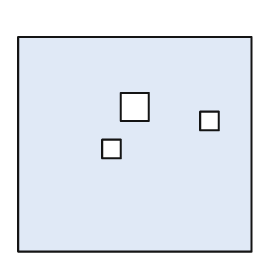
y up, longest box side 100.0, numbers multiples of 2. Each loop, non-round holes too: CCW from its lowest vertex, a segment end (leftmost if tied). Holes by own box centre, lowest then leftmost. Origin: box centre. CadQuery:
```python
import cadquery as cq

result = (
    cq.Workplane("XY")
    .moveTo(-50.0, -46.0)
    .lineTo(50.0, -46.0)
    .lineTo(50.0, 46.0)
    .lineTo(-50.0, 46.0)
    .close()
    .moveTo(-14.0, -6.0)
    .lineTo(-6.0, -6.0)
    .lineTo(-6.0, 2.0)
    .lineTo(-14.0, 2.0)
    .close()
    .moveTo(28.0, 6.0)
    .lineTo(36.0, 6.0)
    .lineTo(36.0, 14.0)
    .lineTo(28.0, 14.0)
    .close()
    .moveTo(-6.0, 10.0)
    .lineTo(6.0, 10.0)
    .lineTo(6.0, 22.0)
    .lineTo(-6.0, 22.0)
    .close()
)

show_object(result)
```